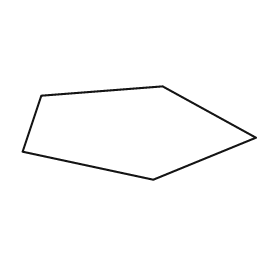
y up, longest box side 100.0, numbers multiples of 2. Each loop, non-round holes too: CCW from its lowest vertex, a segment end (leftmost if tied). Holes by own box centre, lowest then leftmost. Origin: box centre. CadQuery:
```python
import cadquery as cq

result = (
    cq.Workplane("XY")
    .moveTo(6.0, -20.0)
    .lineTo(50.0, -2.0)
    .lineTo(10.0, 20.0)
    .lineTo(-42.0, 16.0)
    .lineTo(-50.0, -8.0)
    .close()
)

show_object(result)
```